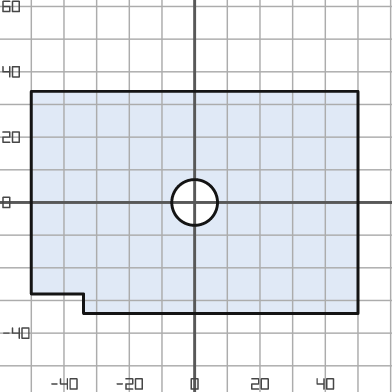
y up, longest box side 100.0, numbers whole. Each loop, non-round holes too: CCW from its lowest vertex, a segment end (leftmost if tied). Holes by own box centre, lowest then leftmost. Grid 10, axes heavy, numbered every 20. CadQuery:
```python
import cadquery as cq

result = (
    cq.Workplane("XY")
    .moveTo(-34.0, -34.0)
    .lineTo(50.0, -34.0)
    .lineTo(50.0, 34.0)
    .lineTo(-50.0, 34.0)
    .lineTo(-50.0, -28.0)
    .lineTo(-34.0, -28.0)
    .close()
    .moveTo(0.0, 0.0)
    .circle(7.0)
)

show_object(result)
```